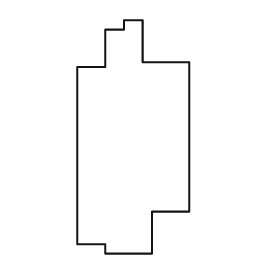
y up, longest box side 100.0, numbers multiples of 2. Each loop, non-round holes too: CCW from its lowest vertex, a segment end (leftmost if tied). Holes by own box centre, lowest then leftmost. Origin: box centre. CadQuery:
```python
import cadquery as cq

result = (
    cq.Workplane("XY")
    .moveTo(-12.0, -50.0)
    .lineTo(8.0, -50.0)
    .lineTo(8.0, -32.0)
    .lineTo(24.0, -32.0)
    .lineTo(24.0, 32.0)
    .lineTo(4.0, 32.0)
    .lineTo(4.0, 50.0)
    .lineTo(-4.0, 50.0)
    .lineTo(-4.0, 46.0)
    .lineTo(-12.0, 46.0)
    .lineTo(-12.0, 30.0)
    .lineTo(-24.0, 30.0)
    .lineTo(-24.0, -46.0)
    .lineTo(-12.0, -46.0)
    .close()
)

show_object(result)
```